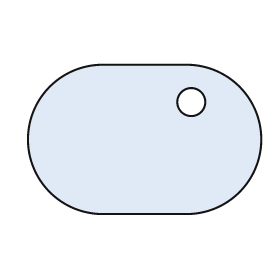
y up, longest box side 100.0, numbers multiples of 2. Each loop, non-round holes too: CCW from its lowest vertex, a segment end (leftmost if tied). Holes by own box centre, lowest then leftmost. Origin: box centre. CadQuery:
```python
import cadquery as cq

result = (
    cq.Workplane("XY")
    .moveTo(-18.0, -32.0)
    .lineTo(18.0, -32.0)
    .threePointArc((50.0, 0.0), (18.0, 32.0))
    .lineTo(-18.0, 32.0)
    .threePointArc((-50.0, 0.0), (-18.0, -32.0))
    .close()
    .moveTo(20.0, 16.0)
    .circle(6.0)
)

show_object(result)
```